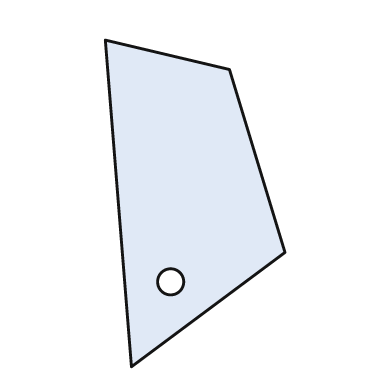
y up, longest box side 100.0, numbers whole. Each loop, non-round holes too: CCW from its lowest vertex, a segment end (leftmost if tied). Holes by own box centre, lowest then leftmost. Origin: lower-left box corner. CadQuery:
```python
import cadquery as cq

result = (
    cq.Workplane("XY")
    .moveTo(8.0, 0.0)
    .lineTo(55.0, 35.0)
    .lineTo(38.0, 91.0)
    .lineTo(0.0, 100.0)
    .close()
    .moveTo(20.0, 26.0)
    .circle(4.0)
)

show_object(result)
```